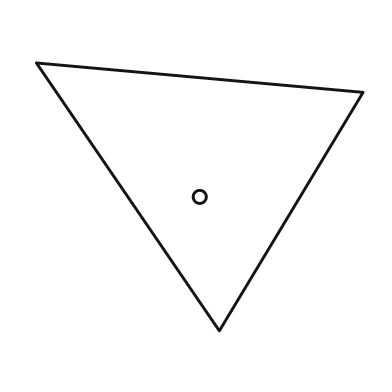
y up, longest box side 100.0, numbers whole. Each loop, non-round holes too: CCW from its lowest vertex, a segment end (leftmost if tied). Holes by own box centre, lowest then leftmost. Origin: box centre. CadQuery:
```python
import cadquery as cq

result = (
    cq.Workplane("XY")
    .moveTo(6.0, -41.0)
    .lineTo(50.0, 32.0)
    .lineTo(-50.0, 41.0)
    .close()
    .moveTo(0.0, 0.0)
    .circle(2.0)
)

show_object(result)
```